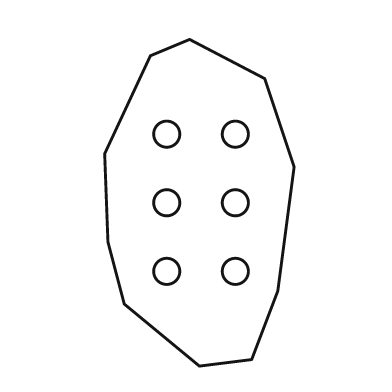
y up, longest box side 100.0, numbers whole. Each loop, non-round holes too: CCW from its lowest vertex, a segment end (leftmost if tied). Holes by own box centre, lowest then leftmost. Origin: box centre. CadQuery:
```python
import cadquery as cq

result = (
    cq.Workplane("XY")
    .moveTo(0.0, -50.0)
    .lineTo(16.0, -48.0)
    .lineTo(24.0, -27.0)
    .lineTo(29.0, 11.0)
    .lineTo(20.0, 38.0)
    .lineTo(-3.0, 50.0)
    .lineTo(-15.0, 45.0)
    .lineTo(-29.0, 15.0)
    .lineTo(-28.0, -12.0)
    .lineTo(-23.0, -31.0)
    .close()
    .moveTo(-10.0, -21.0)
    .circle(4.0)
    .moveTo(11.0, -21.0)
    .circle(4.0)
    .moveTo(-10.0, 0.0)
    .circle(4.0)
    .moveTo(11.0, 0.0)
    .circle(4.0)
    .moveTo(-10.0, 21.0)
    .circle(4.0)
    .moveTo(11.0, 21.0)
    .circle(4.0)
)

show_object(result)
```